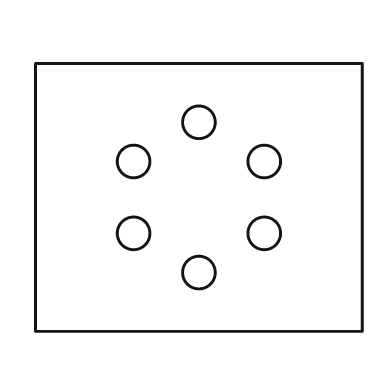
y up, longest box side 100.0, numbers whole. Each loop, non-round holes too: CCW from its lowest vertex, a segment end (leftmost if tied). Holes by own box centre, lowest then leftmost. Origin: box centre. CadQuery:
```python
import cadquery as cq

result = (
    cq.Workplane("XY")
    .moveTo(-50.0, -41.0)
    .lineTo(50.0, -41.0)
    .lineTo(50.0, 41.0)
    .lineTo(-50.0, 41.0)
    .close()
    .moveTo(0.0, -23.0)
    .circle(5.0)
    .moveTo(-20.0, -11.0)
    .circle(5.0)
    .moveTo(20.0, -11.0)
    .circle(5.0)
    .moveTo(-20.0, 11.0)
    .circle(5.0)
    .moveTo(20.0, 11.0)
    .circle(5.0)
    .moveTo(0.0, 23.0)
    .circle(5.0)
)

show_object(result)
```